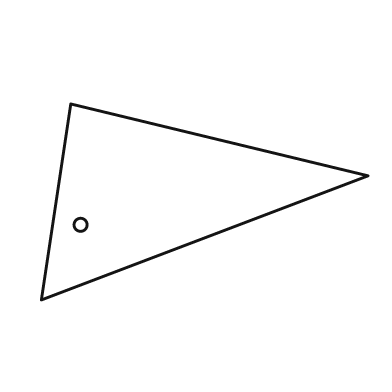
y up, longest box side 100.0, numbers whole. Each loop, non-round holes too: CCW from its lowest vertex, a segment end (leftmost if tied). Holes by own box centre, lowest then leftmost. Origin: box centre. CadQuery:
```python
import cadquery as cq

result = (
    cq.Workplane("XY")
    .moveTo(-50.0, -30.0)
    .lineTo(50.0, 8.0)
    .lineTo(-41.0, 30.0)
    .close()
    .moveTo(-38.0, -7.0)
    .circle(2.0)
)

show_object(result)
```